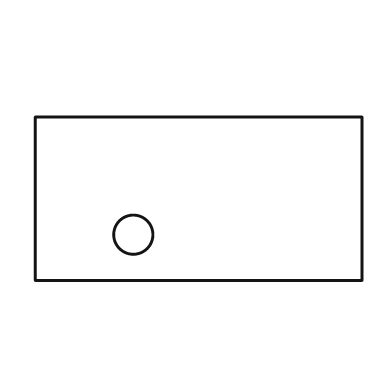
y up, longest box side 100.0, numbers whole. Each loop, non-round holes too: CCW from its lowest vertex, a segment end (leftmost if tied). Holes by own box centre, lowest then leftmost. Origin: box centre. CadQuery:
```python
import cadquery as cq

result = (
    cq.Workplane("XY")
    .moveTo(-50.0, -25.0)
    .lineTo(50.0, -25.0)
    .lineTo(50.0, 25.0)
    .lineTo(-50.0, 25.0)
    .close()
    .moveTo(-20.0, -11.0)
    .circle(6.0)
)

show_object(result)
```